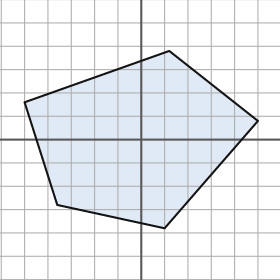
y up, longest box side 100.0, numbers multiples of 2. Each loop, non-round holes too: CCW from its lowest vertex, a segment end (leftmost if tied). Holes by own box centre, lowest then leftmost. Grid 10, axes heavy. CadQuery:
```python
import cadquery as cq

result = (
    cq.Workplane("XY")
    .moveTo(10.0, -38.0)
    .lineTo(50.0, 8.0)
    .lineTo(12.0, 38.0)
    .lineTo(-50.0, 16.0)
    .lineTo(-36.0, -28.0)
    .close()
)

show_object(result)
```